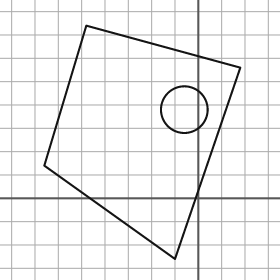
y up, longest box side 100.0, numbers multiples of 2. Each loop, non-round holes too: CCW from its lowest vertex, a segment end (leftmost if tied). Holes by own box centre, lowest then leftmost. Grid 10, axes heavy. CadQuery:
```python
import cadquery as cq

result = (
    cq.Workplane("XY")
    .moveTo(-10.0, -26.0)
    .lineTo(18.0, 56.0)
    .lineTo(-48.0, 74.0)
    .lineTo(-66.0, 14.0)
    .close()
    .moveTo(-6.0, 38.0)
    .circle(10.0)
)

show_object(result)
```